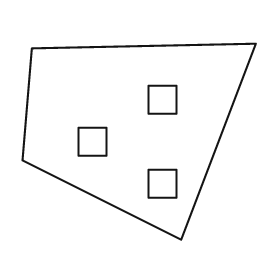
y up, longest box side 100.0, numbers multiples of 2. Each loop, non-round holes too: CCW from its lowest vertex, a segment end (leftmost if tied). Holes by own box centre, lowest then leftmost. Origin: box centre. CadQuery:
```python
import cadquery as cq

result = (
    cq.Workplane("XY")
    .moveTo(18.0, -42.0)
    .lineTo(50.0, 42.0)
    .lineTo(-46.0, 40.0)
    .lineTo(-50.0, -8.0)
    .close()
    .moveTo(4.0, -24.0)
    .lineTo(16.0, -24.0)
    .lineTo(16.0, -12.0)
    .lineTo(4.0, -12.0)
    .close()
    .moveTo(-26.0, -6.0)
    .lineTo(-14.0, -6.0)
    .lineTo(-14.0, 6.0)
    .lineTo(-26.0, 6.0)
    .close()
    .moveTo(4.0, 12.0)
    .lineTo(16.0, 12.0)
    .lineTo(16.0, 24.0)
    .lineTo(4.0, 24.0)
    .close()
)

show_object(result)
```